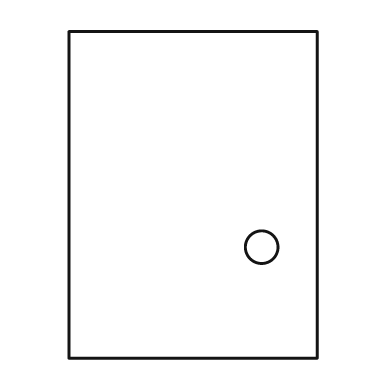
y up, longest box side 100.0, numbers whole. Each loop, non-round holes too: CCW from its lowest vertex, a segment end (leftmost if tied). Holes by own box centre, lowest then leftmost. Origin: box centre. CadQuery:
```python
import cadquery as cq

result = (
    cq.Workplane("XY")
    .moveTo(-38.0, -50.0)
    .lineTo(38.0, -50.0)
    .lineTo(38.0, 50.0)
    .lineTo(-38.0, 50.0)
    .close()
    .moveTo(21.0, -16.0)
    .circle(5.0)
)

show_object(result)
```